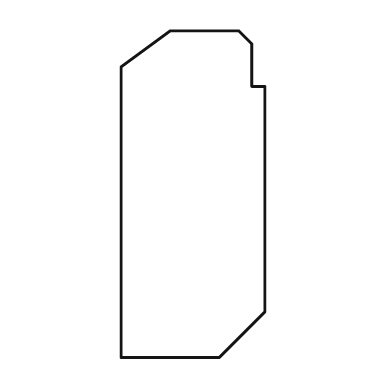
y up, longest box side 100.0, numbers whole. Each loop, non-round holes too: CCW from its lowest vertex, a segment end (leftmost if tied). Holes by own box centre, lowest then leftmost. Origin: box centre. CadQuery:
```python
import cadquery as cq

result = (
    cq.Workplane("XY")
    .moveTo(-22.0, -50.0)
    .lineTo(8.0, -50.0)
    .lineTo(22.0, -36.0)
    .lineTo(22.0, 33.0)
    .lineTo(18.0, 33.0)
    .lineTo(18.0, 46.0)
    .lineTo(14.0, 50.0)
    .lineTo(-7.0, 50.0)
    .lineTo(-22.0, 39.0)
    .close()
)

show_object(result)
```